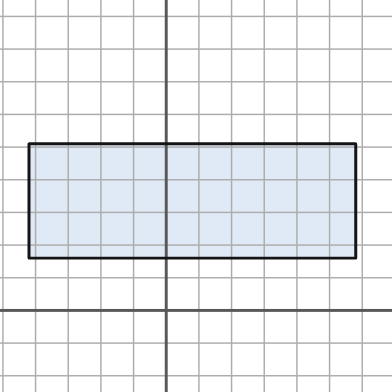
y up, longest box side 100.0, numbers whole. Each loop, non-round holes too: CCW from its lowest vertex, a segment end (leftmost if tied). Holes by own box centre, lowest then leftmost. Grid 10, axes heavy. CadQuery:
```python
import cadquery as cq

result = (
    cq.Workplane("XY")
    .moveTo(-42.0, 16.0)
    .lineTo(58.0, 16.0)
    .lineTo(58.0, 51.0)
    .lineTo(-42.0, 51.0)
    .close()
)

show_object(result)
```